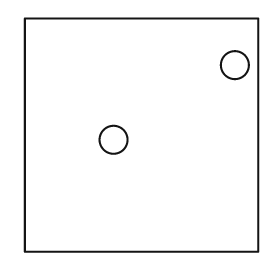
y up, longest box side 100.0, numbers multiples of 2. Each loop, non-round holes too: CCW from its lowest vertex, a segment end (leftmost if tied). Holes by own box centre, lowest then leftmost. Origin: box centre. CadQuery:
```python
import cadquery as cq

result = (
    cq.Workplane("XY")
    .moveTo(-50.0, -50.0)
    .lineTo(50.0, -50.0)
    .lineTo(50.0, 50.0)
    .lineTo(-50.0, 50.0)
    .close()
    .moveTo(-12.0, -2.0)
    .circle(6.0)
    .moveTo(40.0, 30.0)
    .circle(6.0)
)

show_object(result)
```